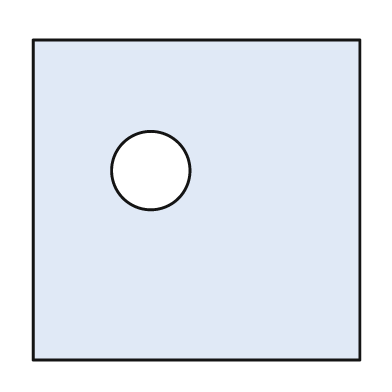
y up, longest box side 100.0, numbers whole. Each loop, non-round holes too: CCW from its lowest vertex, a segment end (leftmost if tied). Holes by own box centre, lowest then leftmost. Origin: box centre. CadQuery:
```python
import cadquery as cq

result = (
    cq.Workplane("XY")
    .moveTo(-50.0, -49.0)
    .lineTo(50.0, -49.0)
    .lineTo(50.0, 49.0)
    .lineTo(-50.0, 49.0)
    .close()
    .moveTo(-14.0, 9.0)
    .circle(12.0)
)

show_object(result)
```